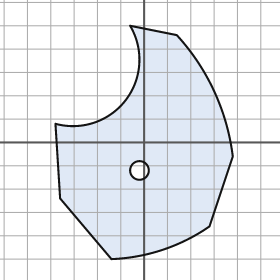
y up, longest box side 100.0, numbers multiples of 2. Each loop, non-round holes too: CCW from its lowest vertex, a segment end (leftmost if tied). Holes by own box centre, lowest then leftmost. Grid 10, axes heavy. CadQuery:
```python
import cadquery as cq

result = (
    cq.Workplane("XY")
    .moveTo(-14.0, -50.0)
    .threePointArc((8.0, -46.0), (28.0, -36.0))
    .lineTo(38.0, -6.0)
    .threePointArc((30.0, 22.0), (14.0, 46.0))
    .lineTo(-6.0, 50.0)
    .threePointArc((-8.0, 18.0), (-38.0, 8.0))
    .lineTo(-36.0, -24.0)
    .close()
    .moveTo(-2.0, -12.0)
    .circle(4.0)
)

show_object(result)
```